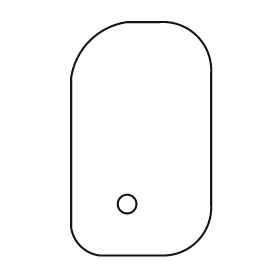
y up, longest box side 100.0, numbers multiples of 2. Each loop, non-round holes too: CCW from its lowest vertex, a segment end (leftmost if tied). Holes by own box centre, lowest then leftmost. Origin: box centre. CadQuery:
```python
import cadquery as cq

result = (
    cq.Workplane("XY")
    .moveTo(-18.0, -50.0)
    .lineTo(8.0, -50.0)
    .threePointArc((24.0, -44.0), (30.0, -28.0))
    .lineTo(30.0, 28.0)
    .threePointArc((24.0, 44.0), (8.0, 50.0))
    .lineTo(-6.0, 50.0)
    .threePointArc((-22.0, 42.0), (-30.0, 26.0))
    .lineTo(-30.0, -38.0)
    .threePointArc((-26.0, -46.0), (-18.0, -50.0))
    .close()
    .moveTo(-6.0, -28.0)
    .circle(4.0)
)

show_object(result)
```